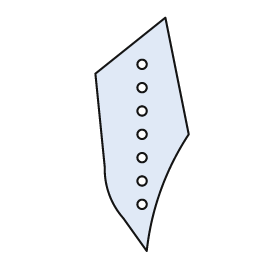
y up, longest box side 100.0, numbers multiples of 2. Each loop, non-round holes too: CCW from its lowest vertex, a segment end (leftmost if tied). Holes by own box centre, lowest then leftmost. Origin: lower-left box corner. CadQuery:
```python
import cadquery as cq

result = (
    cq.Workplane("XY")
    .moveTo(22.0, 0.0)
    .threePointArc((28.0, 26.0), (40.0, 50.0))
    .lineTo(30.0, 100.0)
    .lineTo(0.0, 76.0)
    .lineTo(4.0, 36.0)
    .threePointArc((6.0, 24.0), (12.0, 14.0))
    .close()
    .moveTo(20.0, 20.0)
    .circle(2.0)
    .moveTo(20.0, 30.0)
    .circle(2.0)
    .moveTo(20.0, 40.0)
    .circle(2.0)
    .moveTo(20.0, 50.0)
    .circle(2.0)
    .moveTo(20.0, 60.0)
    .circle(2.0)
    .moveTo(20.0, 70.0)
    .circle(2.0)
    .moveTo(20.0, 80.0)
    .circle(2.0)
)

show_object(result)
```